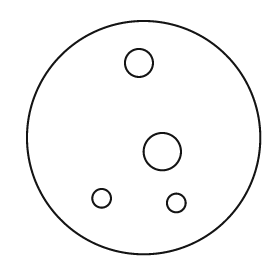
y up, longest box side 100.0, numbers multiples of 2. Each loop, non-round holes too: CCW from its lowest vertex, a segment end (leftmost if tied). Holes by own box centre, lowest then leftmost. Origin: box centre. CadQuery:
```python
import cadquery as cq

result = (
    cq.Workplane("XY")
    .moveTo(0.0, 0.0)
    .circle(50.0)
    .moveTo(14.0, -28.0)
    .circle(4.0)
    .moveTo(-18.0, -26.0)
    .circle(4.0)
    .moveTo(8.0, -6.0)
    .circle(8.0)
    .moveTo(-2.0, 32.0)
    .circle(6.0)
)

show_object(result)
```